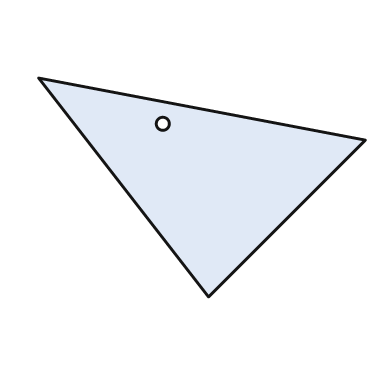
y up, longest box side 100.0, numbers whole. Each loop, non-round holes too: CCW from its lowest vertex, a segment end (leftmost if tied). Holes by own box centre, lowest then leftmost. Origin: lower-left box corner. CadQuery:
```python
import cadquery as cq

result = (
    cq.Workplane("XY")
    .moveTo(52.0, 0.0)
    .lineTo(100.0, 48.0)
    .lineTo(0.0, 67.0)
    .close()
    .moveTo(38.0, 53.0)
    .circle(2.0)
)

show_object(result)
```